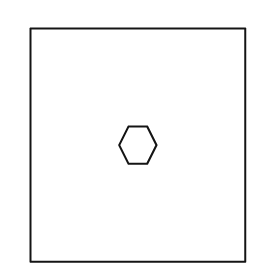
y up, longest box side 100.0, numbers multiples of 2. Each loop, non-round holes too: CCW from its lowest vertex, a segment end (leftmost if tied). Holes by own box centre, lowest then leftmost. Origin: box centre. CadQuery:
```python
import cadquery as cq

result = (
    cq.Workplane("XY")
    .moveTo(-46.0, -50.0)
    .lineTo(46.0, -50.0)
    .lineTo(46.0, 50.0)
    .lineTo(-46.0, 50.0)
    .close()
    .moveTo(-4.0, -8.0)
    .lineTo(4.0, -8.0)
    .lineTo(8.0, 0.0)
    .lineTo(4.0, 8.0)
    .lineTo(-4.0, 8.0)
    .lineTo(-8.0, 0.0)
    .close()
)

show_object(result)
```